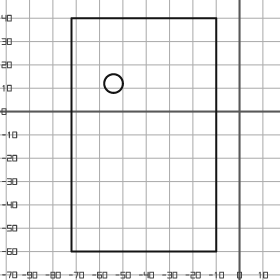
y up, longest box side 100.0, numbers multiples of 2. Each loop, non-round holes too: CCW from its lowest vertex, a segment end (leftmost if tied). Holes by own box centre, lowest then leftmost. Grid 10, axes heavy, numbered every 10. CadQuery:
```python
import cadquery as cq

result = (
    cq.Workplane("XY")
    .moveTo(-72.0, -60.0)
    .lineTo(-10.0, -60.0)
    .lineTo(-10.0, 40.0)
    .lineTo(-72.0, 40.0)
    .close()
    .moveTo(-54.0, 12.0)
    .circle(4.0)
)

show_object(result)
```